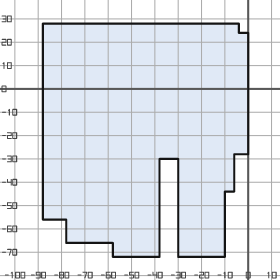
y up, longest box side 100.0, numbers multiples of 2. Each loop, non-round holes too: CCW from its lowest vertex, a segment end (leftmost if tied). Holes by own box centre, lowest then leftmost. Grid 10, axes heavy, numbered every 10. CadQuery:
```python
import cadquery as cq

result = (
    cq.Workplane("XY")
    .moveTo(-58.0, -72.0)
    .lineTo(-38.0, -72.0)
    .lineTo(-38.0, -30.0)
    .lineTo(-30.0, -30.0)
    .lineTo(-30.0, -72.0)
    .lineTo(-10.0, -72.0)
    .lineTo(-10.0, -44.0)
    .lineTo(-6.0, -44.0)
    .lineTo(-6.0, -28.0)
    .lineTo(0.0, -28.0)
    .lineTo(0.0, 24.0)
    .lineTo(-4.0, 24.0)
    .lineTo(-4.0, 28.0)
    .lineTo(-88.0, 28.0)
    .lineTo(-88.0, -56.0)
    .lineTo(-78.0, -56.0)
    .lineTo(-78.0, -66.0)
    .lineTo(-58.0, -66.0)
    .close()
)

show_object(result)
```